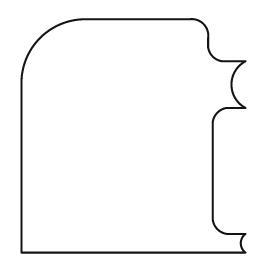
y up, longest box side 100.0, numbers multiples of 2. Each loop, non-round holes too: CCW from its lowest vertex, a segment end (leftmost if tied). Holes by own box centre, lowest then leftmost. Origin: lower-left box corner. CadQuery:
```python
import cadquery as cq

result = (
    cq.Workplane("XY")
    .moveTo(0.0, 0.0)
    .lineTo(96.0, 0.0)
    .threePointArc((94.0, 4.0), (96.0, 8.0))
    .lineTo(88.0, 8.0)
    .threePointArc((84.0, 10.0), (82.0, 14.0))
    .lineTo(82.0, 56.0)
    .threePointArc((84.0, 60.0), (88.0, 62.0))
    .lineTo(96.0, 62.0)
    .threePointArc((90.0, 72.0), (96.0, 82.0))
    .lineTo(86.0, 82.0)
    .threePointArc((82.0, 84.0), (80.0, 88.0))
    .lineTo(80.0, 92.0)
    .threePointArc((78.0, 98.0), (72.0, 100.0))
    .lineTo(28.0, 100.0)
    .threePointArc((8.0, 92.0), (0.0, 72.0))
    .close()
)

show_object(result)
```